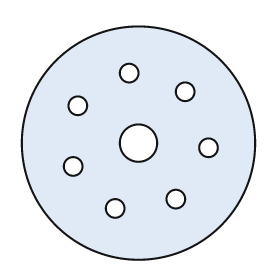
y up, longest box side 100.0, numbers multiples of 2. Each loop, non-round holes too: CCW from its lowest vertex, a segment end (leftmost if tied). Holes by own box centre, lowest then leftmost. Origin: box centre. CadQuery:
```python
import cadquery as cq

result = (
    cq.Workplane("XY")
    .moveTo(0.0, 0.0)
    .circle(50.0)
    .moveTo(-10.0, -28.0)
    .circle(4.0)
    .moveTo(16.0, -24.0)
    .circle(4.0)
    .moveTo(-28.0, -10.0)
    .circle(4.0)
    .moveTo(30.0, -2.0)
    .circle(4.0)
    .moveTo(0.0, 0.0)
    .circle(8.0)
    .moveTo(-26.0, 16.0)
    .circle(4.0)
    .moveTo(20.0, 22.0)
    .circle(4.0)
    .moveTo(-4.0, 30.0)
    .circle(4.0)
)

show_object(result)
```